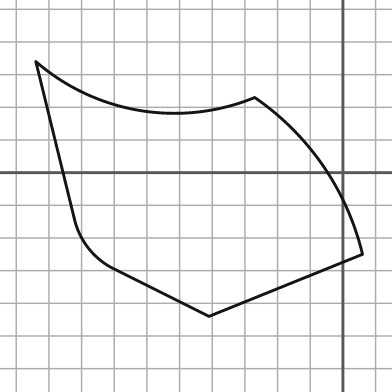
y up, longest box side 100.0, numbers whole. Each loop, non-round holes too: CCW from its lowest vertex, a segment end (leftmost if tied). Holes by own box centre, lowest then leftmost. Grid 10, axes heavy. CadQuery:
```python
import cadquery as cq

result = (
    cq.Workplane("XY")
    .moveTo(-41.0, -44.0)
    .lineTo(6.0, -25.0)
    .threePointArc((-6.0, 2.0), (-27.0, 23.0))
    .threePointArc((-62.0, 19.0), (-94.0, 34.0))
    .lineTo(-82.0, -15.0)
    .threePointArc((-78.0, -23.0), (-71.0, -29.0))
    .close()
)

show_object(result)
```